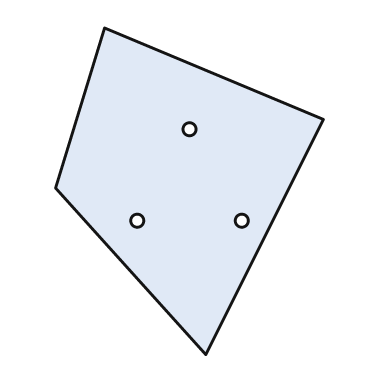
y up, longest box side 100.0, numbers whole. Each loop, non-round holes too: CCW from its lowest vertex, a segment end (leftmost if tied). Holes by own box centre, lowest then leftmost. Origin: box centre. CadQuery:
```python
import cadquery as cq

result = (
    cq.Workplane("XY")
    .moveTo(5.0, -50.0)
    .lineTo(41.0, 22.0)
    .lineTo(-26.0, 50.0)
    .lineTo(-41.0, 1.0)
    .close()
    .moveTo(-16.0, -9.0)
    .circle(2.0)
    .moveTo(16.0, -9.0)
    .circle(2.0)
    .moveTo(0.0, 19.0)
    .circle(2.0)
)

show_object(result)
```